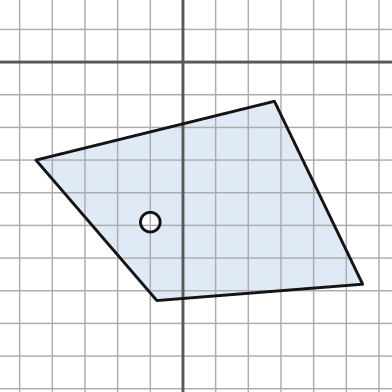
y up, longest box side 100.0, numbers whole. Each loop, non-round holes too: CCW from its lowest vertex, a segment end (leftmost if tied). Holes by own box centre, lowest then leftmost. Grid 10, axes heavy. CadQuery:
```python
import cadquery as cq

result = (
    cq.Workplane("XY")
    .moveTo(-8.0, -73.0)
    .lineTo(55.0, -68.0)
    .lineTo(28.0, -12.0)
    .lineTo(-45.0, -30.0)
    .close()
    .moveTo(-10.0, -49.0)
    .circle(3.0)
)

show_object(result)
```